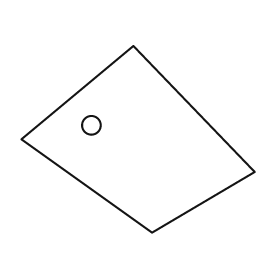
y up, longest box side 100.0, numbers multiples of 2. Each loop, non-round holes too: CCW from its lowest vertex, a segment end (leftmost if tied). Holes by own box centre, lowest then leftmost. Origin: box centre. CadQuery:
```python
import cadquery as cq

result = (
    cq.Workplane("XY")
    .moveTo(6.0, -40.0)
    .lineTo(50.0, -14.0)
    .lineTo(-2.0, 40.0)
    .lineTo(-50.0, 0.0)
    .close()
    .moveTo(-20.0, 6.0)
    .circle(4.0)
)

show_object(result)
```